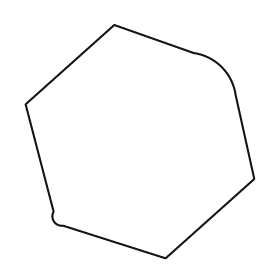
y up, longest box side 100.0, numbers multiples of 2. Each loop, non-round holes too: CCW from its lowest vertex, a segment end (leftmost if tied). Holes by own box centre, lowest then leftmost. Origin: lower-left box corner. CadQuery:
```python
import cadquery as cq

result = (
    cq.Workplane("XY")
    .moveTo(60.0, 0.0)
    .lineTo(98.0, 34.0)
    .lineTo(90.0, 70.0)
    .threePointArc((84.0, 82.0), (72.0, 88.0))
    .lineTo(38.0, 100.0)
    .lineTo(0.0, 66.0)
    .lineTo(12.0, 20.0)
    .threePointArc((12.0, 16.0), (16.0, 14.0))
    .close()
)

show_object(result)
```